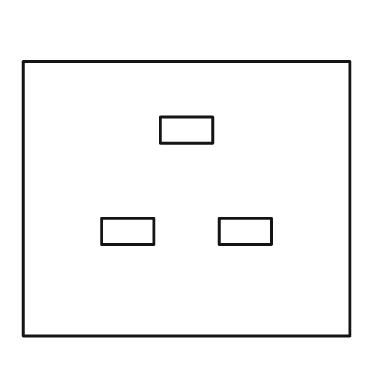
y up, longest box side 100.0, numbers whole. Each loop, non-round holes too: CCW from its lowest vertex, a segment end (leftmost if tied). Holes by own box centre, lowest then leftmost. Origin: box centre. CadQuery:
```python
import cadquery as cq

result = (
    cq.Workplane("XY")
    .moveTo(-50.0, -42.0)
    .lineTo(50.0, -42.0)
    .lineTo(50.0, 42.0)
    .lineTo(-50.0, 42.0)
    .close()
    .moveTo(-26.0, -14.0)
    .lineTo(-10.0, -14.0)
    .lineTo(-10.0, -6.0)
    .lineTo(-26.0, -6.0)
    .close()
    .moveTo(10.0, -14.0)
    .lineTo(26.0, -14.0)
    .lineTo(26.0, -6.0)
    .lineTo(10.0, -6.0)
    .close()
    .moveTo(-8.0, 17.0)
    .lineTo(8.0, 17.0)
    .lineTo(8.0, 25.0)
    .lineTo(-8.0, 25.0)
    .close()
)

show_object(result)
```